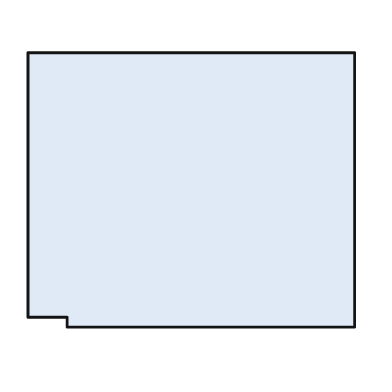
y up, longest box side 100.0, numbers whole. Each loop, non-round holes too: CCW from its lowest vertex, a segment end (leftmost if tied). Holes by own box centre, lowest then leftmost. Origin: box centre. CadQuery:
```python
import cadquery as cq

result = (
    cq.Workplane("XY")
    .moveTo(-38.0, -42.0)
    .lineTo(50.0, -42.0)
    .lineTo(50.0, 42.0)
    .lineTo(-50.0, 42.0)
    .lineTo(-50.0, -39.0)
    .lineTo(-38.0, -39.0)
    .close()
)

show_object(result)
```